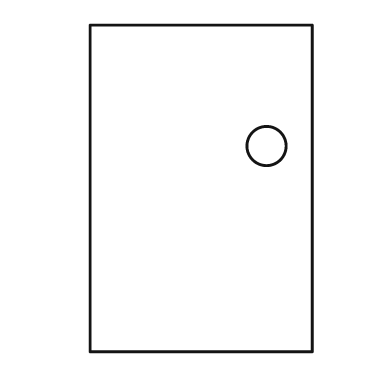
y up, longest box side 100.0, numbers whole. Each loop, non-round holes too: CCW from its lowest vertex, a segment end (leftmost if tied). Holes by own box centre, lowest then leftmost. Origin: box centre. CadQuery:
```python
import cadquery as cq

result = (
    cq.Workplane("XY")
    .moveTo(-34.0, -50.0)
    .lineTo(34.0, -50.0)
    .lineTo(34.0, 50.0)
    .lineTo(-34.0, 50.0)
    .close()
    .moveTo(20.0, 13.0)
    .circle(6.0)
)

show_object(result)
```